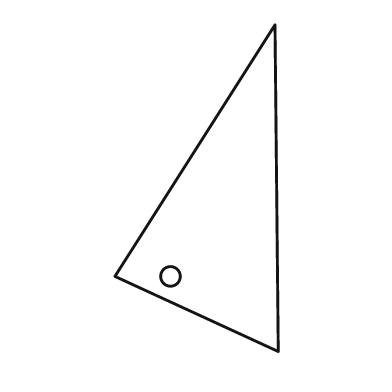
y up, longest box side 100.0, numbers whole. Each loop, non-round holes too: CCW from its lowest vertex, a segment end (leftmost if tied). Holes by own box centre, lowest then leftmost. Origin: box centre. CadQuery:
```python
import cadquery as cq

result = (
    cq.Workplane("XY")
    .moveTo(25.0, -50.0)
    .lineTo(24.0, 50.0)
    .lineTo(-25.0, -27.0)
    .close()
    .moveTo(-8.0, -27.0)
    .circle(3.0)
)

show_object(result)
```